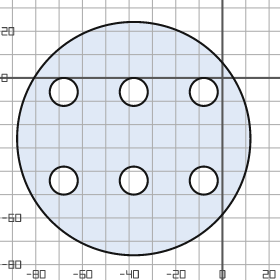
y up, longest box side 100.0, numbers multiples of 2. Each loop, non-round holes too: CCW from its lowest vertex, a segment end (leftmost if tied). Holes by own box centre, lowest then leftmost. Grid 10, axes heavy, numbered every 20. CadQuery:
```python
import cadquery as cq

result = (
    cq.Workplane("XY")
    .moveTo(-38.0, -26.0)
    .circle(50.0)
    .moveTo(-68.0, -44.0)
    .circle(6.0)
    .moveTo(-38.0, -44.0)
    .circle(6.0)
    .moveTo(-8.0, -44.0)
    .circle(6.0)
    .moveTo(-68.0, -6.0)
    .circle(6.0)
    .moveTo(-38.0, -6.0)
    .circle(6.0)
    .moveTo(-8.0, -6.0)
    .circle(6.0)
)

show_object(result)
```